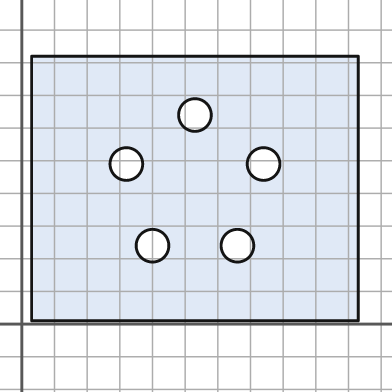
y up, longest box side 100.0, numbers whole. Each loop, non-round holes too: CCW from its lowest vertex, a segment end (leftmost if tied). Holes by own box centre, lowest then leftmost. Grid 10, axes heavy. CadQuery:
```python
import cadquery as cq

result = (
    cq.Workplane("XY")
    .moveTo(3.0, 1.0)
    .lineTo(103.0, 1.0)
    .lineTo(103.0, 82.0)
    .lineTo(3.0, 82.0)
    .close()
    .moveTo(40.0, 24.0)
    .circle(5.0)
    .moveTo(66.0, 24.0)
    .circle(5.0)
    .moveTo(32.0, 49.0)
    .circle(5.0)
    .moveTo(74.0, 49.0)
    .circle(5.0)
    .moveTo(53.0, 64.0)
    .circle(5.0)
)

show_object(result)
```